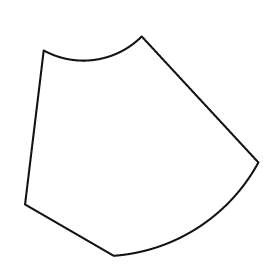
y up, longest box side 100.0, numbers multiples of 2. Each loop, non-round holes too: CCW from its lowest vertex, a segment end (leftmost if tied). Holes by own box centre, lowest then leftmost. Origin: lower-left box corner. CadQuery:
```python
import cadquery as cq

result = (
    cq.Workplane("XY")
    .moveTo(38.0, 0.0)
    .threePointArc((74.0, 12.0), (100.0, 40.0))
    .lineTo(50.0, 94.0)
    .threePointArc((30.0, 84.0), (8.0, 88.0))
    .lineTo(0.0, 22.0)
    .close()
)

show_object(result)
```